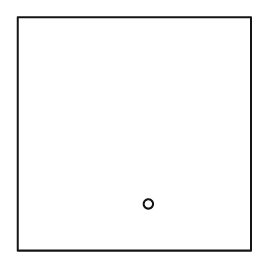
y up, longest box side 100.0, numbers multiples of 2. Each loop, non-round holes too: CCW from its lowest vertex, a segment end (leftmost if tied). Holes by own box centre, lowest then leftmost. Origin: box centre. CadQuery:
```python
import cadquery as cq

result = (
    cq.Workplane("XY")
    .moveTo(-50.0, -50.0)
    .lineTo(50.0, -50.0)
    .lineTo(50.0, 50.0)
    .lineTo(-50.0, 50.0)
    .close()
    .moveTo(6.0, -30.0)
    .circle(2.0)
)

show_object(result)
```